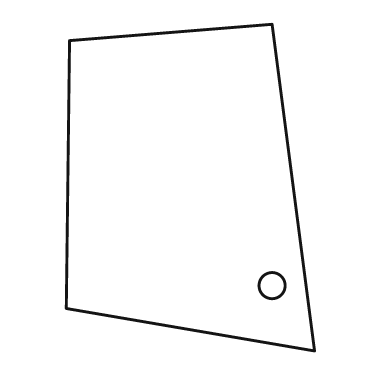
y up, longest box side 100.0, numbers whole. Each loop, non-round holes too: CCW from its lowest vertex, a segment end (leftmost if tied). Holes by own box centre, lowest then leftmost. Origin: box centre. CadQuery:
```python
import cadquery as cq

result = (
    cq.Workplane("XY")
    .moveTo(38.0, -50.0)
    .lineTo(25.0, 50.0)
    .lineTo(-37.0, 45.0)
    .lineTo(-38.0, -37.0)
    .close()
    .moveTo(25.0, -30.0)
    .circle(4.0)
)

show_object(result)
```